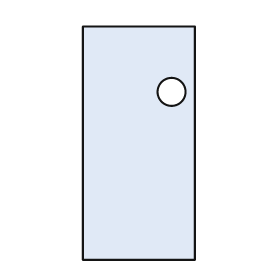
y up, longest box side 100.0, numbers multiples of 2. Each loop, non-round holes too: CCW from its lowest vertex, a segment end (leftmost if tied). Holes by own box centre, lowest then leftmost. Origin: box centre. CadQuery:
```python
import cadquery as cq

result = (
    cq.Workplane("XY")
    .moveTo(-24.0, -50.0)
    .lineTo(24.0, -50.0)
    .lineTo(24.0, 50.0)
    .lineTo(-24.0, 50.0)
    .close()
    .moveTo(14.0, 22.0)
    .circle(6.0)
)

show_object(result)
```